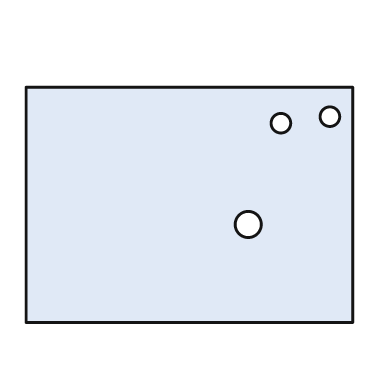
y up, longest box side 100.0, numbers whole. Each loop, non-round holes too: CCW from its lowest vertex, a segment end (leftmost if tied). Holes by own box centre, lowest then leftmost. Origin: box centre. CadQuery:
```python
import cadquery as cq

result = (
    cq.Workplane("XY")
    .moveTo(-50.0, -36.0)
    .lineTo(50.0, -36.0)
    .lineTo(50.0, 36.0)
    .lineTo(-50.0, 36.0)
    .close()
    .moveTo(18.0, -6.0)
    .circle(4.0)
    .moveTo(28.0, 25.0)
    .circle(3.0)
    .moveTo(43.0, 27.0)
    .circle(3.0)
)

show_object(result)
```